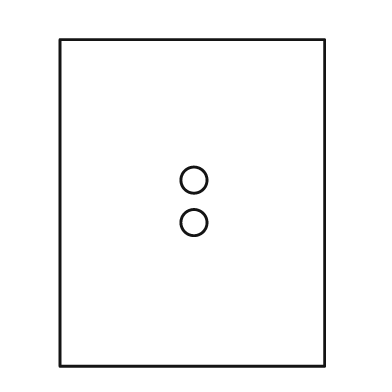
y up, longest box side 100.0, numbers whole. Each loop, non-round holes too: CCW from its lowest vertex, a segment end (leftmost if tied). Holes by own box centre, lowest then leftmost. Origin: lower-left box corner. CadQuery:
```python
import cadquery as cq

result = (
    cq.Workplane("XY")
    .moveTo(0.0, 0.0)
    .lineTo(81.0, 0.0)
    .lineTo(81.0, 100.0)
    .lineTo(0.0, 100.0)
    .close()
    .moveTo(41.0, 44.0)
    .circle(4.0)
    .moveTo(41.0, 57.0)
    .circle(4.0)
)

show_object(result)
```